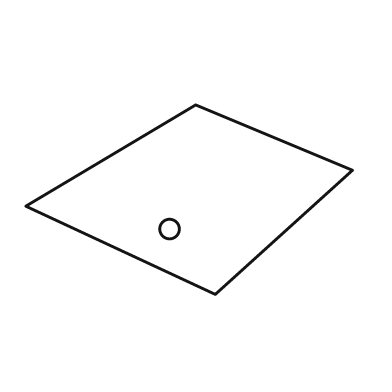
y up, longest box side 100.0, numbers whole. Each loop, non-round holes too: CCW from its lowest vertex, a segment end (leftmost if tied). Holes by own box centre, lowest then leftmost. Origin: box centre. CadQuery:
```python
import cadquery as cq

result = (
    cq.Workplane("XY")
    .moveTo(8.0, -29.0)
    .lineTo(50.0, 9.0)
    .lineTo(2.0, 29.0)
    .lineTo(-50.0, -2.0)
    .close()
    .moveTo(-6.0, -9.0)
    .circle(3.0)
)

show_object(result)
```